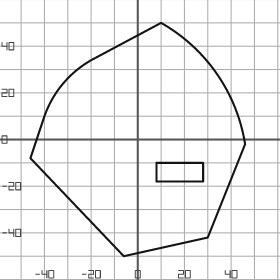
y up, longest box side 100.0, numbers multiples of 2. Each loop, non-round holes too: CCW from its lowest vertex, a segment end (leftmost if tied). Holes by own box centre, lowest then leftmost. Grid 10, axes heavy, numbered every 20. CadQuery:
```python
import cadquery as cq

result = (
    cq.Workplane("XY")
    .moveTo(-6.0, -50.0)
    .lineTo(30.0, -42.0)
    .lineTo(46.0, -2.0)
    .threePointArc((34.0, 28.0), (10.0, 50.0))
    .lineTo(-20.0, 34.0)
    .threePointArc((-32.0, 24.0), (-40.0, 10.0))
    .lineTo(-46.0, -8.0)
    .close()
    .moveTo(8.0, -18.0)
    .lineTo(28.0, -18.0)
    .lineTo(28.0, -10.0)
    .lineTo(8.0, -10.0)
    .close()
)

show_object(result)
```